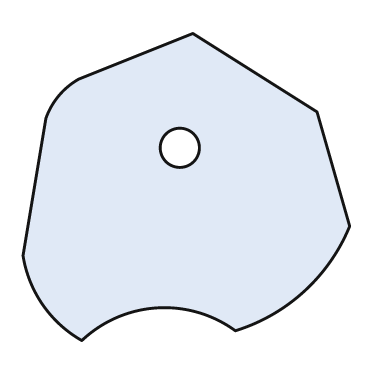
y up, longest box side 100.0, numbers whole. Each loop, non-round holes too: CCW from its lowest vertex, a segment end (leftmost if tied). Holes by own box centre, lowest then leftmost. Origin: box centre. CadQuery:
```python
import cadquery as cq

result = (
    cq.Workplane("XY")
    .moveTo(-32.0, -47.0)
    .threePointArc((-9.0, -37.0), (15.0, -44.0))
    .threePointArc((36.0, -32.0), (50.0, -12.0))
    .lineTo(40.0, 23.0)
    .lineTo(2.0, 47.0)
    .lineTo(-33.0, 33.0)
    .threePointArc((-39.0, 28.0), (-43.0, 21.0))
    .lineTo(-50.0, -21.0)
    .threePointArc((-44.0, -36.0), (-32.0, -47.0))
    .close()
    .moveTo(-2.0, 12.0)
    .circle(6.0)
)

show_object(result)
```